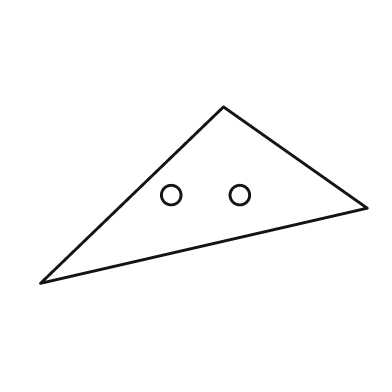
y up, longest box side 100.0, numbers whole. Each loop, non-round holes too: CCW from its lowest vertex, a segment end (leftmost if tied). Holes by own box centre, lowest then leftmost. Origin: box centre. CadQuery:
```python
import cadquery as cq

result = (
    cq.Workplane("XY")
    .moveTo(-50.0, -27.0)
    .lineTo(50.0, -4.0)
    .lineTo(6.0, 27.0)
    .close()
    .moveTo(-10.0, 0.0)
    .circle(3.0)
    .moveTo(11.0, 0.0)
    .circle(3.0)
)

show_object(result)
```